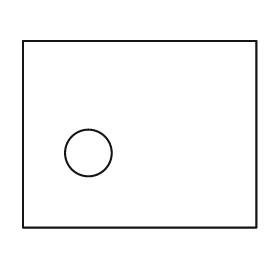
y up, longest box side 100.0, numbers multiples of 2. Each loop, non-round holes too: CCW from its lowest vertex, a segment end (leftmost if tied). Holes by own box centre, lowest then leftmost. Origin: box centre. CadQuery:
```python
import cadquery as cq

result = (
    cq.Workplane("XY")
    .moveTo(-50.0, -40.0)
    .lineTo(50.0, -40.0)
    .lineTo(50.0, 40.0)
    .lineTo(-50.0, 40.0)
    .close()
    .moveTo(-22.0, -8.0)
    .circle(10.0)
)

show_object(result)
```